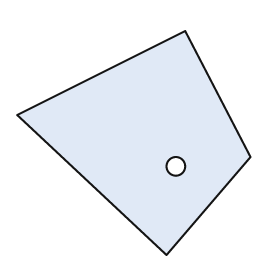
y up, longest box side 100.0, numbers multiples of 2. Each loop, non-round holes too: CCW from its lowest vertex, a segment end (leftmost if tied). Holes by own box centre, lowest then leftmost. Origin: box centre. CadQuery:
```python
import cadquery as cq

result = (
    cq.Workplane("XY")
    .moveTo(14.0, -48.0)
    .lineTo(50.0, -6.0)
    .lineTo(22.0, 48.0)
    .lineTo(-50.0, 12.0)
    .close()
    .moveTo(18.0, -10.0)
    .circle(4.0)
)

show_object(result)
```